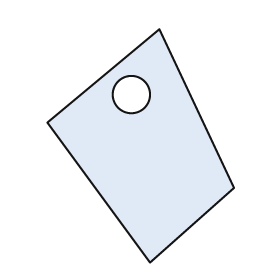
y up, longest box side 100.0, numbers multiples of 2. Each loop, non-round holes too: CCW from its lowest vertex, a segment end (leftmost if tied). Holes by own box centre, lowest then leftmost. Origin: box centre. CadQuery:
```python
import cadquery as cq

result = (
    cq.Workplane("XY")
    .moveTo(4.0, -50.0)
    .lineTo(40.0, -18.0)
    .lineTo(8.0, 50.0)
    .lineTo(-40.0, 10.0)
    .close()
    .moveTo(-4.0, 22.0)
    .circle(8.0)
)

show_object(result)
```